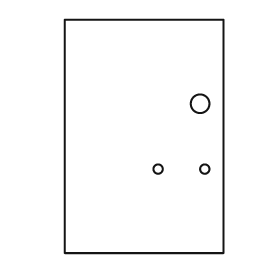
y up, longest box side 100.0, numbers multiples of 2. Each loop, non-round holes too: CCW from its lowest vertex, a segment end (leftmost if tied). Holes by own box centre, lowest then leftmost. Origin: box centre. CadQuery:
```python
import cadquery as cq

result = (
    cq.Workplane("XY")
    .moveTo(-34.0, -50.0)
    .lineTo(34.0, -50.0)
    .lineTo(34.0, 50.0)
    .lineTo(-34.0, 50.0)
    .close()
    .moveTo(6.0, -14.0)
    .circle(2.0)
    .moveTo(26.0, -14.0)
    .circle(2.0)
    .moveTo(24.0, 14.0)
    .circle(4.0)
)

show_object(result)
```